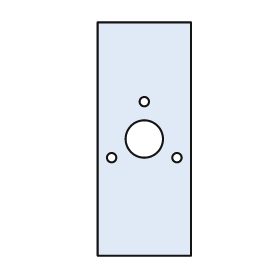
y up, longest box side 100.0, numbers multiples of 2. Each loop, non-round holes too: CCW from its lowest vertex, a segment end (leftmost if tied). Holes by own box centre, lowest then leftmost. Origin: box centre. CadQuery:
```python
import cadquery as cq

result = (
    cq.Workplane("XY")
    .moveTo(-20.0, -50.0)
    .lineTo(20.0, -50.0)
    .lineTo(20.0, 50.0)
    .lineTo(-20.0, 50.0)
    .close()
    .moveTo(-14.0, -8.0)
    .circle(2.0)
    .moveTo(14.0, -8.0)
    .circle(2.0)
    .moveTo(0.0, 0.0)
    .circle(8.0)
    .moveTo(0.0, 16.0)
    .circle(2.0)
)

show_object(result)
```